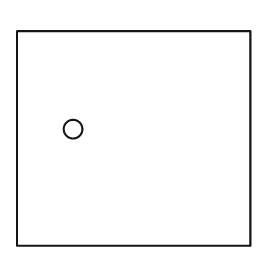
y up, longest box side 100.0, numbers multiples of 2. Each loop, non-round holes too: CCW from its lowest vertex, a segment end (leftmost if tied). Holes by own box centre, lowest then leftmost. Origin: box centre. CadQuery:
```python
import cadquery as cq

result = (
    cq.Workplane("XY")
    .moveTo(-50.0, -46.0)
    .lineTo(50.0, -46.0)
    .lineTo(50.0, 46.0)
    .lineTo(-50.0, 46.0)
    .close()
    .moveTo(-26.0, 4.0)
    .circle(4.0)
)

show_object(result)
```